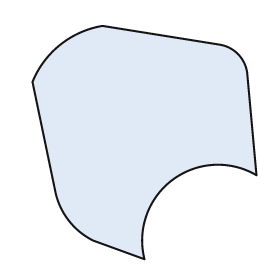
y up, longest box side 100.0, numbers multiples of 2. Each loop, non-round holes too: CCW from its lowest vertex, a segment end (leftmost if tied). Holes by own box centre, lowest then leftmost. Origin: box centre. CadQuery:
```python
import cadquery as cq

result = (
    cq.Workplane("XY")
    .moveTo(0.0, -50.0)
    .threePointArc((12.0, -16.0), (48.0, -14.0))
    .lineTo(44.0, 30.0)
    .threePointArc((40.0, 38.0), (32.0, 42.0))
    .lineTo(-18.0, 50.0)
    .threePointArc((-36.0, 42.0), (-48.0, 26.0))
    .lineTo(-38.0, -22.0)
    .threePointArc((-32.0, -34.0), (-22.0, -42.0))
    .close()
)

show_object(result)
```